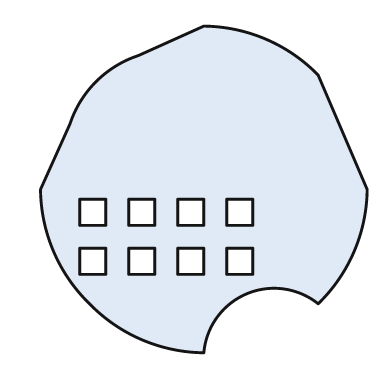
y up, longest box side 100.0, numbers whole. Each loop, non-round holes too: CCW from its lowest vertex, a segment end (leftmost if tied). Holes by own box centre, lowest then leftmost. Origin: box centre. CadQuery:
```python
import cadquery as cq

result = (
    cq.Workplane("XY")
    .moveTo(0.0, -50.0)
    .threePointArc((13.0, -32.0), (35.0, -35.0))
    .threePointArc((46.0, -19.0), (50.0, 0.0))
    .lineTo(35.0, 35.0)
    .threePointArc((19.0, 46.0), (0.0, 50.0))
    .lineTo(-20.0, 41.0)
    .threePointArc((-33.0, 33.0), (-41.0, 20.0))
    .lineTo(-50.0, 0.0)
    .threePointArc((-46.0, -19.0), (-35.0, -35.0))
    .threePointArc((-19.0, -46.0), (0.0, -50.0))
    .close()
    .moveTo(-38.0, -26.0)
    .lineTo(-30.0, -26.0)
    .lineTo(-30.0, -18.0)
    .lineTo(-38.0, -18.0)
    .close()
    .moveTo(-23.0, -26.0)
    .lineTo(-15.0, -26.0)
    .lineTo(-15.0, -18.0)
    .lineTo(-23.0, -18.0)
    .close()
    .moveTo(-8.0, -26.0)
    .lineTo(0.0, -26.0)
    .lineTo(0.0, -18.0)
    .lineTo(-8.0, -18.0)
    .close()
    .moveTo(7.0, -26.0)
    .lineTo(15.0, -26.0)
    .lineTo(15.0, -18.0)
    .lineTo(7.0, -18.0)
    .close()
    .moveTo(-38.0, -11.0)
    .lineTo(-30.0, -11.0)
    .lineTo(-30.0, -3.0)
    .lineTo(-38.0, -3.0)
    .close()
    .moveTo(-23.0, -11.0)
    .lineTo(-15.0, -11.0)
    .lineTo(-15.0, -3.0)
    .lineTo(-23.0, -3.0)
    .close()
    .moveTo(-8.0, -11.0)
    .lineTo(0.0, -11.0)
    .lineTo(0.0, -3.0)
    .lineTo(-8.0, -3.0)
    .close()
    .moveTo(7.0, -11.0)
    .lineTo(15.0, -11.0)
    .lineTo(15.0, -3.0)
    .lineTo(7.0, -3.0)
    .close()
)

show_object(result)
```